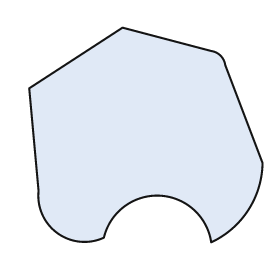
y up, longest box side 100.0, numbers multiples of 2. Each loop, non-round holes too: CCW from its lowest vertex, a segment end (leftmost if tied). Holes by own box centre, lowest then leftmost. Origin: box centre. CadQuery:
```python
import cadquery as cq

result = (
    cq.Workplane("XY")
    .moveTo(28.0, -46.0)
    .threePointArc((44.0, -32.0), (50.0, -12.0))
    .lineTo(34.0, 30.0)
    .threePointArc((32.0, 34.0), (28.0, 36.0))
    .lineTo(-10.0, 46.0)
    .lineTo(-50.0, 20.0)
    .lineTo(-46.0, -24.0)
    .threePointArc((-38.0, -42.0), (-18.0, -44.0))
    .threePointArc((6.0, -26.0), (28.0, -46.0))
    .close()
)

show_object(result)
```